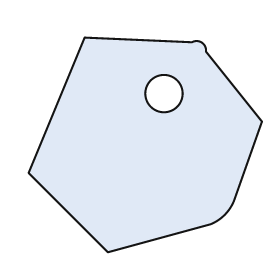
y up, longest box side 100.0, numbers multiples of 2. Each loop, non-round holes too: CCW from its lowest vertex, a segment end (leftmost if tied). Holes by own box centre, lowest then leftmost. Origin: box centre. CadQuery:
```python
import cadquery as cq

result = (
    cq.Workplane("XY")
    .moveTo(-16.0, -46.0)
    .lineTo(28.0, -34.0)
    .threePointArc((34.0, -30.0), (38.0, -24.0))
    .lineTo(50.0, 10.0)
    .lineTo(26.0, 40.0)
    .threePointArc((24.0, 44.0), (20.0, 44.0))
    .lineTo(-26.0, 46.0)
    .lineTo(-50.0, -12.0)
    .close()
    .moveTo(8.0, 22.0)
    .circle(8.0)
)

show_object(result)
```